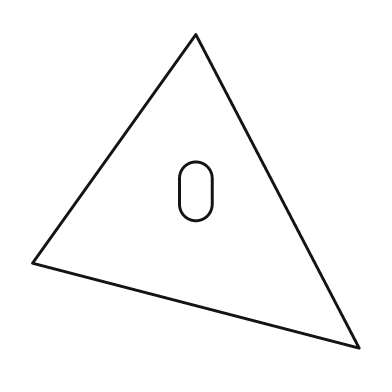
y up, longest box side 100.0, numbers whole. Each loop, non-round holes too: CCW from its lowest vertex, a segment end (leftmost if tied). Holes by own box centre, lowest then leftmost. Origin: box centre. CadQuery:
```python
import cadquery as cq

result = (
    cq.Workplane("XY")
    .moveTo(50.0, -48.0)
    .lineTo(0.0, 48.0)
    .lineTo(-50.0, -22.0)
    .close()
    .moveTo(-5.0, -4.0)
    .threePointArc((0.0, -9.0), (5.0, -4.0))
    .lineTo(5.0, 4.0)
    .threePointArc((0.0, 9.0), (-5.0, 4.0))
    .close()
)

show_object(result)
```